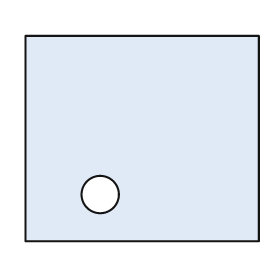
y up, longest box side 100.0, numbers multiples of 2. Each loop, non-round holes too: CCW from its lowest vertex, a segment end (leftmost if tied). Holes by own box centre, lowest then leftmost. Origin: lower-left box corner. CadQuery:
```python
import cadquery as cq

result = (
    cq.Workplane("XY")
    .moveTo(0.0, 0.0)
    .lineTo(100.0, 0.0)
    .lineTo(100.0, 88.0)
    .lineTo(0.0, 88.0)
    .close()
    .moveTo(32.0, 20.0)
    .circle(8.0)
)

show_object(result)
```